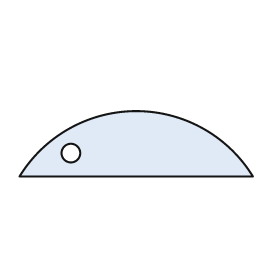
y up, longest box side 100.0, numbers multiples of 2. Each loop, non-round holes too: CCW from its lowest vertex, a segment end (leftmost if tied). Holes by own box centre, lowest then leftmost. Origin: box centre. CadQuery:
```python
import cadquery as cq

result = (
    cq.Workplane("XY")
    .moveTo(-50.0, -14.0)
    .lineTo(50.0, -14.0)
    .threePointArc((0.0, 14.0), (-50.0, -14.0))
    .close()
    .moveTo(-28.0, -4.0)
    .circle(4.0)
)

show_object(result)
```